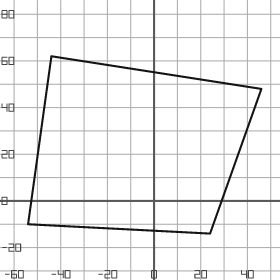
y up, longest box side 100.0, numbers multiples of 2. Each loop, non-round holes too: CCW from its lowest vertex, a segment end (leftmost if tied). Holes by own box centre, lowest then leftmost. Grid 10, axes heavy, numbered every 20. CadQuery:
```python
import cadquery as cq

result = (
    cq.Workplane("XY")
    .moveTo(24.0, -14.0)
    .lineTo(46.0, 48.0)
    .lineTo(-44.0, 62.0)
    .lineTo(-54.0, -10.0)
    .close()
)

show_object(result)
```